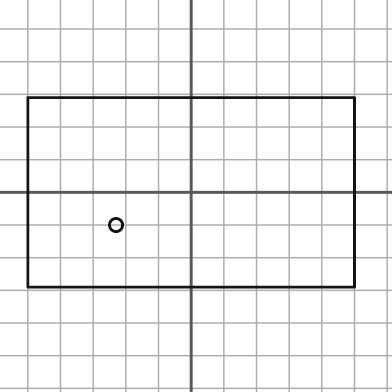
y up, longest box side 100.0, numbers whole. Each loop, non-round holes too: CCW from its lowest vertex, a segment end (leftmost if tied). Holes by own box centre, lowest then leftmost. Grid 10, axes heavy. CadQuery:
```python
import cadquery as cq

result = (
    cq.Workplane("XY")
    .moveTo(-50.0, -29.0)
    .lineTo(50.0, -29.0)
    .lineTo(50.0, 29.0)
    .lineTo(-50.0, 29.0)
    .close()
    .moveTo(-23.0, -10.0)
    .circle(2.0)
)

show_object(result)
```